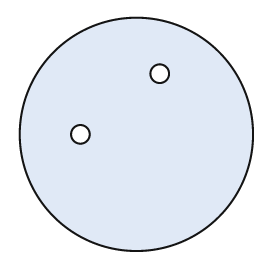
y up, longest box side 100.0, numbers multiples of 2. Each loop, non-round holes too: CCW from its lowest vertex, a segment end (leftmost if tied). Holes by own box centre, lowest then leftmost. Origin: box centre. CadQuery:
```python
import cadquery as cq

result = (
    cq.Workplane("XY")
    .moveTo(0.0, 0.0)
    .circle(50.0)
    .moveTo(-24.0, 0.0)
    .circle(4.0)
    .moveTo(10.0, 26.0)
    .circle(4.0)
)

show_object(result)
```